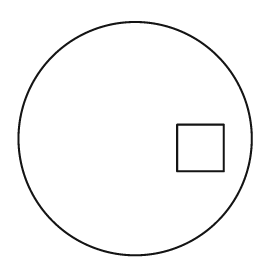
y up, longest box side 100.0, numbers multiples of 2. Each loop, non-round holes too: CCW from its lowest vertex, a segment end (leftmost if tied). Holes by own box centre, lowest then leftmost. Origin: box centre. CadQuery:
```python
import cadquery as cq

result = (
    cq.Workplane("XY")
    .moveTo(0.0, 0.0)
    .circle(50.0)
    .moveTo(18.0, -14.0)
    .lineTo(38.0, -14.0)
    .lineTo(38.0, 6.0)
    .lineTo(18.0, 6.0)
    .close()
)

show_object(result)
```